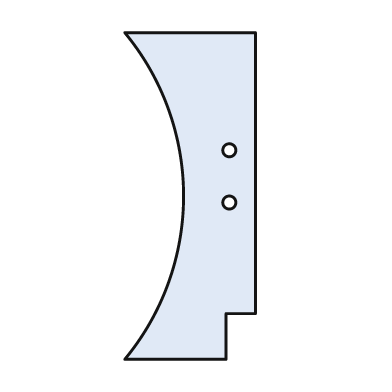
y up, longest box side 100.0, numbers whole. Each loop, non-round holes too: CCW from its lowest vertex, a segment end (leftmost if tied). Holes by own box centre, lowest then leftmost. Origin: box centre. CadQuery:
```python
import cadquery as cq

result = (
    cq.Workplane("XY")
    .moveTo(-20.0, -50.0)
    .lineTo(11.0, -50.0)
    .lineTo(11.0, -36.0)
    .lineTo(20.0, -36.0)
    .lineTo(20.0, 50.0)
    .lineTo(-20.0, 50.0)
    .threePointArc((-2.0, 0.0), (-20.0, -50.0))
    .close()
    .moveTo(12.0, -2.0)
    .circle(2.0)
    .moveTo(12.0, 14.0)
    .circle(2.0)
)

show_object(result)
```